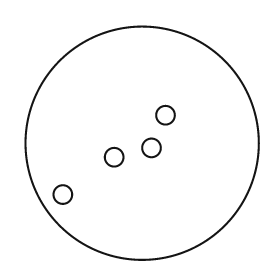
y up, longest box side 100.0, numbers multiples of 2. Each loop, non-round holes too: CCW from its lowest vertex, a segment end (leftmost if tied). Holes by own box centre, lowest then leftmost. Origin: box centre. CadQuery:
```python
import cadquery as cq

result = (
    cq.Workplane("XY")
    .moveTo(0.0, 0.0)
    .circle(50.0)
    .moveTo(-34.0, -22.0)
    .circle(4.0)
    .moveTo(-12.0, -6.0)
    .circle(4.0)
    .moveTo(4.0, -2.0)
    .circle(4.0)
    .moveTo(10.0, 12.0)
    .circle(4.0)
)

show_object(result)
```